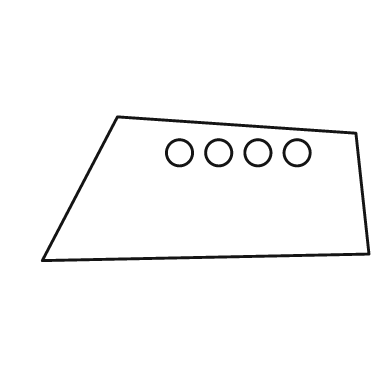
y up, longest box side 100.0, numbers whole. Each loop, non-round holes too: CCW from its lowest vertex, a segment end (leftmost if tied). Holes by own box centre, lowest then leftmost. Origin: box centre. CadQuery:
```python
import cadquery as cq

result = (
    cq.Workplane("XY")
    .moveTo(-50.0, -22.0)
    .lineTo(50.0, -20.0)
    .lineTo(46.0, 17.0)
    .lineTo(-27.0, 22.0)
    .close()
    .moveTo(-8.0, 11.0)
    .circle(4.0)
    .moveTo(4.0, 11.0)
    .circle(4.0)
    .moveTo(16.0, 11.0)
    .circle(4.0)
    .moveTo(28.0, 11.0)
    .circle(4.0)
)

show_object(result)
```